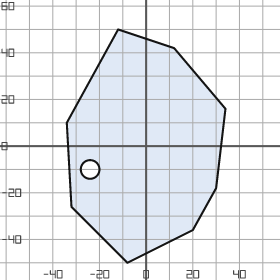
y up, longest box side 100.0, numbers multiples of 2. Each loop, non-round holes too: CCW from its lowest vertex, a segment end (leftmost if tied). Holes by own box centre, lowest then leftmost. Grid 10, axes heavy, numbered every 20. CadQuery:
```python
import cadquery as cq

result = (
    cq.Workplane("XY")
    .moveTo(-8.0, -50.0)
    .lineTo(20.0, -36.0)
    .lineTo(30.0, -18.0)
    .lineTo(34.0, 16.0)
    .lineTo(12.0, 42.0)
    .lineTo(-12.0, 50.0)
    .lineTo(-34.0, 10.0)
    .lineTo(-32.0, -26.0)
    .close()
    .moveTo(-24.0, -10.0)
    .circle(4.0)
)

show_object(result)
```